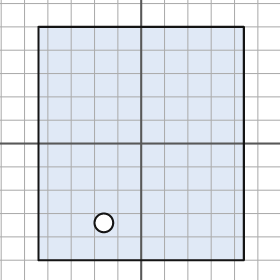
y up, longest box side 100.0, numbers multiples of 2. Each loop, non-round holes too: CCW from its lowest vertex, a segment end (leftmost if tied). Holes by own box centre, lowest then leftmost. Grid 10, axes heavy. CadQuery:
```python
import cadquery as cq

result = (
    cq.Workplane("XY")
    .moveTo(-44.0, -50.0)
    .lineTo(44.0, -50.0)
    .lineTo(44.0, 50.0)
    .lineTo(-44.0, 50.0)
    .close()
    .moveTo(-16.0, -34.0)
    .circle(4.0)
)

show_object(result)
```